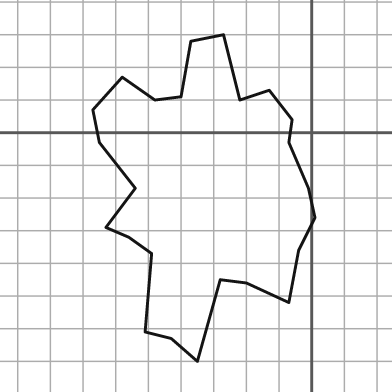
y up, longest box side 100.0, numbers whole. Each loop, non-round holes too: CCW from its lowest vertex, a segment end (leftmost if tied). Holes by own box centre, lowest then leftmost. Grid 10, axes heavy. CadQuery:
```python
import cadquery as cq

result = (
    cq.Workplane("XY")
    .moveTo(-35.0, -70.0)
    .lineTo(-28.0, -45.0)
    .lineTo(-20.0, -46.0)
    .lineTo(-7.0, -52.0)
    .lineTo(-4.0, -36.0)
    .lineTo(1.0, -26.0)
    .lineTo(-1.0, -17.0)
    .lineTo(-7.0, -3.0)
    .lineTo(-6.0, 4.0)
    .lineTo(-13.0, 13.0)
    .lineTo(-22.0, 10.0)
    .lineTo(-27.0, 30.0)
    .lineTo(-37.0, 28.0)
    .lineTo(-40.0, 11.0)
    .lineTo(-48.0, 10.0)
    .lineTo(-58.0, 17.0)
    .lineTo(-67.0, 7.0)
    .lineTo(-65.0, -3.0)
    .lineTo(-54.0, -17.0)
    .lineTo(-63.0, -29.0)
    .lineTo(-56.0, -32.0)
    .lineTo(-49.0, -37.0)
    .lineTo(-51.0, -61.0)
    .lineTo(-43.0, -63.0)
    .close()
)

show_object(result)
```